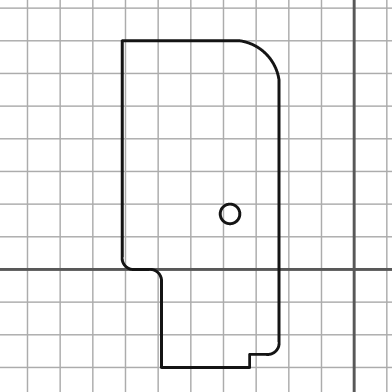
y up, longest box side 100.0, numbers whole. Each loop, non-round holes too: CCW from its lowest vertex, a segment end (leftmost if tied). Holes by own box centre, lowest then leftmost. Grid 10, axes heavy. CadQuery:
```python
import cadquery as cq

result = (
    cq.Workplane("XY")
    .moveTo(-59.0, -30.0)
    .lineTo(-32.0, -30.0)
    .lineTo(-32.0, -26.0)
    .lineTo(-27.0, -26.0)
    .threePointArc((-24.0, -25.0), (-23.0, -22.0))
    .lineTo(-23.0, 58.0)
    .threePointArc((-27.0, 66.0), (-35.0, 70.0))
    .lineTo(-71.0, 70.0)
    .lineTo(-71.0, 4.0)
    .threePointArc((-70.0, 1.0), (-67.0, 0.0))
    .lineTo(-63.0, 0.0)
    .threePointArc((-60.0, -1.0), (-59.0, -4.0))
    .close()
    .moveTo(-38.0, 17.0)
    .circle(3.0)
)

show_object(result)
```